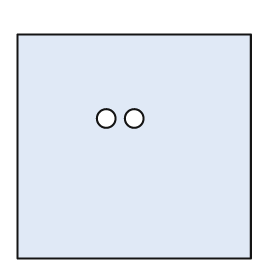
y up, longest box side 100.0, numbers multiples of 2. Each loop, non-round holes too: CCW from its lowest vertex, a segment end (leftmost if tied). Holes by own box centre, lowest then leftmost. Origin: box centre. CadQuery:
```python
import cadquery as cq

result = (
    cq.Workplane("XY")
    .moveTo(-50.0, -48.0)
    .lineTo(50.0, -48.0)
    .lineTo(50.0, 48.0)
    .lineTo(-50.0, 48.0)
    .close()
    .moveTo(-12.0, 12.0)
    .circle(4.0)
    .moveTo(0.0, 12.0)
    .circle(4.0)
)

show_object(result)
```